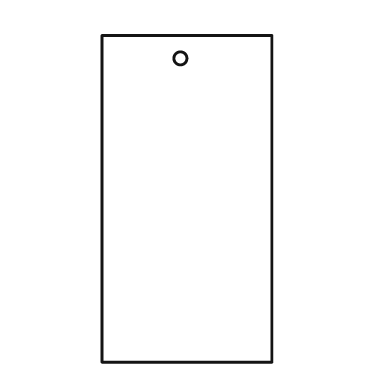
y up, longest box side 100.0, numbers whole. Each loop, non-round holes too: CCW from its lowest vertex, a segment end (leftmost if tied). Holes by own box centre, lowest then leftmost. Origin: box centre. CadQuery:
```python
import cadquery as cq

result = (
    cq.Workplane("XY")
    .moveTo(-26.0, -50.0)
    .lineTo(26.0, -50.0)
    .lineTo(26.0, 50.0)
    .lineTo(-26.0, 50.0)
    .close()
    .moveTo(-2.0, 43.0)
    .circle(2.0)
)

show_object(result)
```